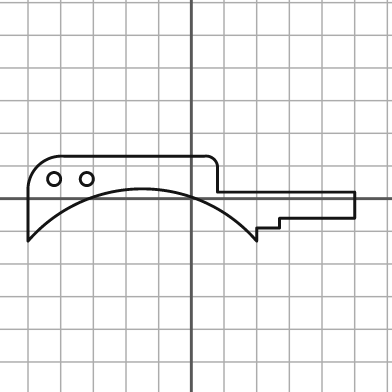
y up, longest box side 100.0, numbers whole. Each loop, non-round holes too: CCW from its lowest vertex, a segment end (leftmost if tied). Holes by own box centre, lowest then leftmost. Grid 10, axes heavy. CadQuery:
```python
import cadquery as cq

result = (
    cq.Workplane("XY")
    .moveTo(-50.0, -13.0)
    .threePointArc((-15.0, 3.0), (20.0, -13.0))
    .lineTo(20.0, -9.0)
    .lineTo(27.0, -9.0)
    .lineTo(27.0, -6.0)
    .lineTo(50.0, -6.0)
    .lineTo(50.0, 2.0)
    .lineTo(8.0, 2.0)
    .lineTo(8.0, 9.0)
    .threePointArc((7.0, 12.0), (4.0, 13.0))
    .lineTo(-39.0, 13.0)
    .threePointArc((-47.0, 10.0), (-50.0, 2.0))
    .close()
    .moveTo(-42.0, 6.0)
    .circle(2.0)
    .moveTo(-32.0, 6.0)
    .circle(2.0)
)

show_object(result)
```